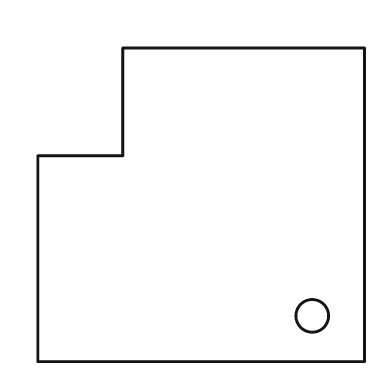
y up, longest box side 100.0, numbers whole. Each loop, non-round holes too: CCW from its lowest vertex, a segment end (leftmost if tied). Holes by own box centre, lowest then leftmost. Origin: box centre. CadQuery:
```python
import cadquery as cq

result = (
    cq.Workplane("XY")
    .moveTo(-50.0, -48.0)
    .lineTo(50.0, -48.0)
    .lineTo(50.0, 48.0)
    .lineTo(-24.0, 48.0)
    .lineTo(-24.0, 15.0)
    .lineTo(-50.0, 15.0)
    .close()
    .moveTo(34.0, -34.0)
    .circle(5.0)
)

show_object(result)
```